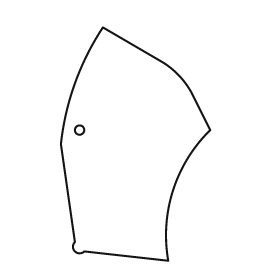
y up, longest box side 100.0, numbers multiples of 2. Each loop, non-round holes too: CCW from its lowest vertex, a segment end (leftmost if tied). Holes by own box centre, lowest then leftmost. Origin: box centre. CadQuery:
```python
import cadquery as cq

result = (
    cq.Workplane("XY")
    .moveTo(14.0, -50.0)
    .threePointArc((16.0, -20.0), (32.0, 6.0))
    .lineTo(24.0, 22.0)
    .threePointArc((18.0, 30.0), (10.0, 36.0))
    .lineTo(-14.0, 50.0)
    .threePointArc((-26.0, 26.0), (-32.0, 0.0))
    .lineTo(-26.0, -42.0)
    .threePointArc((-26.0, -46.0), (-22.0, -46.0))
    .close()
    .moveTo(-24.0, 6.0)
    .circle(2.0)
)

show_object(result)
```